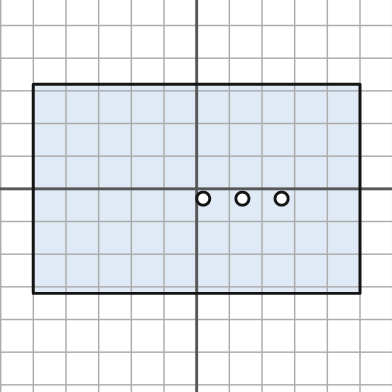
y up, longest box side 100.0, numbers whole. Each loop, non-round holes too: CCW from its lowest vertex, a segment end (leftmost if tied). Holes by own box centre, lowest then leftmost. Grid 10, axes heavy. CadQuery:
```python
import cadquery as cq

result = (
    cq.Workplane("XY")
    .moveTo(-50.0, -32.0)
    .lineTo(50.0, -32.0)
    .lineTo(50.0, 32.0)
    .lineTo(-50.0, 32.0)
    .close()
    .moveTo(2.0, -3.0)
    .circle(2.0)
    .moveTo(14.0, -3.0)
    .circle(2.0)
    .moveTo(26.0, -3.0)
    .circle(2.0)
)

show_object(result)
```